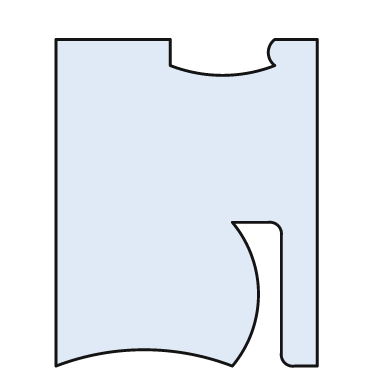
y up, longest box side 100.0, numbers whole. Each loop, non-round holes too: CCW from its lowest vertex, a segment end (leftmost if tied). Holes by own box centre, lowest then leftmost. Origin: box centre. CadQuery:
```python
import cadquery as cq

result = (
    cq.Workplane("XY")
    .moveTo(-40.0, -50.0)
    .threePointArc((-13.0, -45.0), (14.0, -50.0))
    .threePointArc((22.0, -28.0), (14.0, -6.0))
    .lineTo(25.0, -6.0)
    .threePointArc((28.0, -7.0), (29.0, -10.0))
    .lineTo(29.0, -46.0)
    .threePointArc((30.0, -49.0), (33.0, -50.0))
    .lineTo(40.0, -50.0)
    .lineTo(40.0, 50.0)
    .lineTo(27.0, 50.0)
    .threePointArc((25.0, 46.0), (27.0, 42.0))
    .threePointArc((11.0, 39.0), (-5.0, 42.0))
    .lineTo(-5.0, 50.0)
    .lineTo(-40.0, 50.0)
    .close()
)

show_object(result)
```